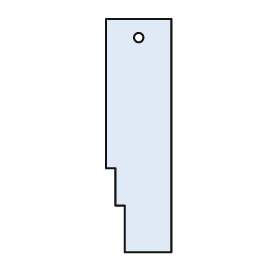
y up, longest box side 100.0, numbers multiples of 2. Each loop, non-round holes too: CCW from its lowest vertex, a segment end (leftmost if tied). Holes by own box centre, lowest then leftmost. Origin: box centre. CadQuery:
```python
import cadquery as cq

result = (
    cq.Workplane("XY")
    .moveTo(-6.0, -50.0)
    .lineTo(14.0, -50.0)
    .lineTo(14.0, 50.0)
    .lineTo(-14.0, 50.0)
    .lineTo(-14.0, -14.0)
    .lineTo(-10.0, -14.0)
    .lineTo(-10.0, -30.0)
    .lineTo(-6.0, -30.0)
    .close()
    .moveTo(0.0, 42.0)
    .circle(2.0)
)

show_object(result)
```